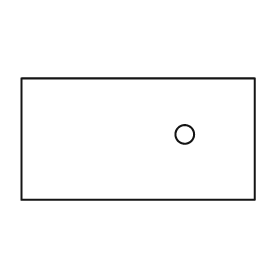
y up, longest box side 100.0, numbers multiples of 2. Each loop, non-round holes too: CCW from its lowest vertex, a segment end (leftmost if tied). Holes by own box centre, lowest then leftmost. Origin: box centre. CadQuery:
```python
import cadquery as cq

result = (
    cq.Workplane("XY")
    .moveTo(-50.0, -26.0)
    .lineTo(50.0, -26.0)
    .lineTo(50.0, 26.0)
    .lineTo(-50.0, 26.0)
    .close()
    .moveTo(20.0, 2.0)
    .circle(4.0)
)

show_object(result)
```